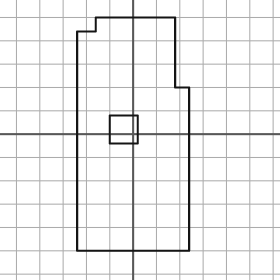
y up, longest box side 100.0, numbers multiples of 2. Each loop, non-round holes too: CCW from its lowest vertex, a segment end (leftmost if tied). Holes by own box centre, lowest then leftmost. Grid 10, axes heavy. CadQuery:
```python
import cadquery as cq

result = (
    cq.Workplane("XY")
    .moveTo(-24.0, -50.0)
    .lineTo(24.0, -50.0)
    .lineTo(24.0, 20.0)
    .lineTo(18.0, 20.0)
    .lineTo(18.0, 50.0)
    .lineTo(-16.0, 50.0)
    .lineTo(-16.0, 44.0)
    .lineTo(-24.0, 44.0)
    .close()
    .moveTo(-10.0, -4.0)
    .lineTo(2.0, -4.0)
    .lineTo(2.0, 8.0)
    .lineTo(-10.0, 8.0)
    .close()
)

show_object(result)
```